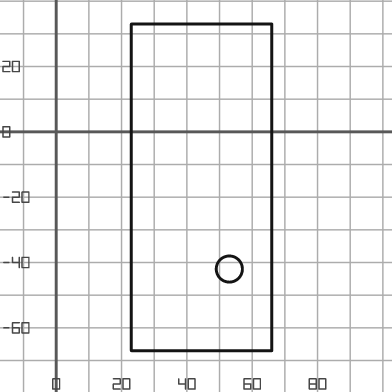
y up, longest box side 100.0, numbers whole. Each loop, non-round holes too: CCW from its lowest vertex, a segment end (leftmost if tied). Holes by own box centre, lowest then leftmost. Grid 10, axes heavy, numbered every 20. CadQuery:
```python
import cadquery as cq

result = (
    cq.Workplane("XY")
    .moveTo(23.0, -67.0)
    .lineTo(66.0, -67.0)
    .lineTo(66.0, 33.0)
    .lineTo(23.0, 33.0)
    .close()
    .moveTo(53.0, -42.0)
    .circle(4.0)
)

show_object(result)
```